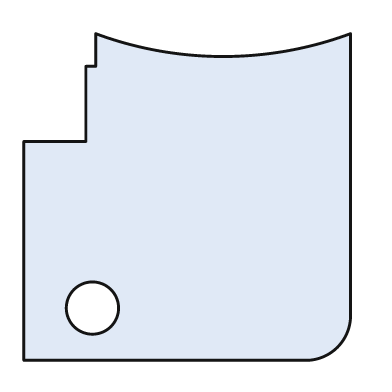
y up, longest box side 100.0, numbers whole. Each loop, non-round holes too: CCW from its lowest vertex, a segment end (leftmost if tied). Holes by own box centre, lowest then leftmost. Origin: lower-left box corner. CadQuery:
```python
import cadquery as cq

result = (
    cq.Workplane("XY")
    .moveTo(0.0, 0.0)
    .lineTo(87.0, 0.0)
    .threePointArc((96.0, 4.0), (100.0, 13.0))
    .lineTo(100.0, 100.0)
    .threePointArc((61.0, 93.0), (22.0, 100.0))
    .lineTo(22.0, 90.0)
    .lineTo(19.0, 90.0)
    .lineTo(19.0, 67.0)
    .lineTo(0.0, 67.0)
    .close()
    .moveTo(21.0, 16.0)
    .circle(8.0)
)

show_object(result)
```